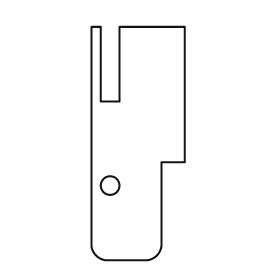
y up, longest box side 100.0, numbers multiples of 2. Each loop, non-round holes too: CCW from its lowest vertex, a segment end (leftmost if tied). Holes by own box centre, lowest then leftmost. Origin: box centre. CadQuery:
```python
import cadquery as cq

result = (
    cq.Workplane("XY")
    .moveTo(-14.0, -50.0)
    .lineTo(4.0, -50.0)
    .threePointArc((8.0, -48.0), (10.0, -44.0))
    .lineTo(10.0, -8.0)
    .lineTo(20.0, -8.0)
    .lineTo(20.0, 50.0)
    .lineTo(-8.0, 50.0)
    .lineTo(-8.0, 18.0)
    .lineTo(-16.0, 18.0)
    .lineTo(-16.0, 50.0)
    .lineTo(-20.0, 50.0)
    .lineTo(-20.0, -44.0)
    .threePointArc((-18.0, -48.0), (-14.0, -50.0))
    .close()
    .moveTo(-12.0, -18.0)
    .circle(4.0)
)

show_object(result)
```